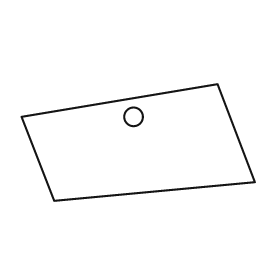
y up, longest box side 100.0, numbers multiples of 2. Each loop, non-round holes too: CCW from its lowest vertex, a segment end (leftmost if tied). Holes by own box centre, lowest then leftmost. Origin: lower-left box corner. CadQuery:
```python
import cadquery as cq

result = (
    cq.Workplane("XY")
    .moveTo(14.0, 0.0)
    .lineTo(100.0, 8.0)
    .lineTo(84.0, 50.0)
    .lineTo(0.0, 36.0)
    .close()
    .moveTo(48.0, 36.0)
    .circle(4.0)
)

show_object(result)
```